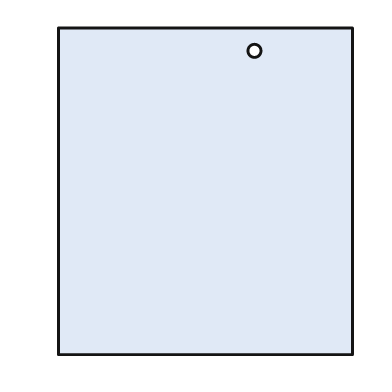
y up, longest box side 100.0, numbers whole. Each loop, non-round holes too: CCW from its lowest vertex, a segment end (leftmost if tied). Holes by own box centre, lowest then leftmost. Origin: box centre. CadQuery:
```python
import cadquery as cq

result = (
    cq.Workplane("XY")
    .moveTo(-45.0, -50.0)
    .lineTo(45.0, -50.0)
    .lineTo(45.0, 50.0)
    .lineTo(-45.0, 50.0)
    .close()
    .moveTo(15.0, 43.0)
    .circle(2.0)
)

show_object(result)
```